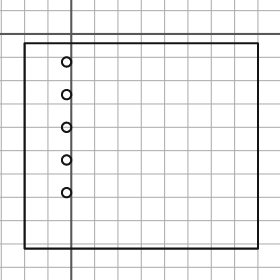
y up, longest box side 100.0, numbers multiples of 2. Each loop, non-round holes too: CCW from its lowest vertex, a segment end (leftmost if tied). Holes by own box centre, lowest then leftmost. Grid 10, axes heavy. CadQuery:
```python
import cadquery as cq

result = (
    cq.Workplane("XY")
    .moveTo(-20.0, -92.0)
    .lineTo(80.0, -92.0)
    .lineTo(80.0, -4.0)
    .lineTo(-20.0, -4.0)
    .close()
    .moveTo(-2.0, -68.0)
    .circle(2.0)
    .moveTo(-2.0, -54.0)
    .circle(2.0)
    .moveTo(-2.0, -40.0)
    .circle(2.0)
    .moveTo(-2.0, -26.0)
    .circle(2.0)
    .moveTo(-2.0, -12.0)
    .circle(2.0)
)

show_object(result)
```